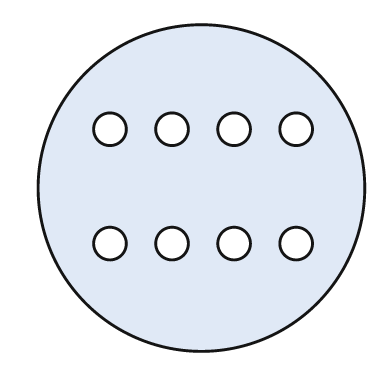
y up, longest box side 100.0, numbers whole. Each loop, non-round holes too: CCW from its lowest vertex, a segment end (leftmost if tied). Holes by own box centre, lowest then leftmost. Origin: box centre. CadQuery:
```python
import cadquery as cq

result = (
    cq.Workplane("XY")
    .moveTo(0.0, 0.0)
    .circle(50.0)
    .moveTo(-28.0, -17.0)
    .circle(5.0)
    .moveTo(-9.0, -17.0)
    .circle(5.0)
    .moveTo(10.0, -17.0)
    .circle(5.0)
    .moveTo(29.0, -17.0)
    .circle(5.0)
    .moveTo(-28.0, 18.0)
    .circle(5.0)
    .moveTo(-9.0, 18.0)
    .circle(5.0)
    .moveTo(10.0, 18.0)
    .circle(5.0)
    .moveTo(29.0, 18.0)
    .circle(5.0)
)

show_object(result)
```